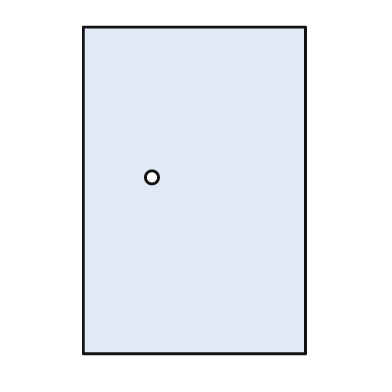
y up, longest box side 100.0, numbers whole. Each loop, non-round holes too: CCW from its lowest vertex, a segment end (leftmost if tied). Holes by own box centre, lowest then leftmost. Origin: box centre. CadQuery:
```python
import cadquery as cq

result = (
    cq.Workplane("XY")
    .moveTo(-34.0, -50.0)
    .lineTo(34.0, -50.0)
    .lineTo(34.0, 50.0)
    .lineTo(-34.0, 50.0)
    .close()
    .moveTo(-13.0, 4.0)
    .circle(2.0)
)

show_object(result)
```